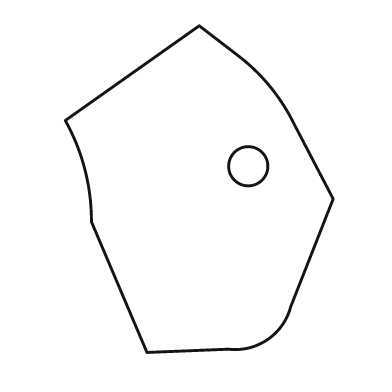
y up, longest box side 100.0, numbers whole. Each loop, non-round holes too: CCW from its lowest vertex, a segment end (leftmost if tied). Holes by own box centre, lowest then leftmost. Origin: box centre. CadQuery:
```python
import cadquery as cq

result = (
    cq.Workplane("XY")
    .moveTo(-16.0, -50.0)
    .lineTo(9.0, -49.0)
    .threePointArc((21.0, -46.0), (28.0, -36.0))
    .lineTo(41.0, -3.0)
    .lineTo(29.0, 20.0)
    .threePointArc((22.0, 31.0), (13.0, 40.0))
    .lineTo(0.0, 50.0)
    .lineTo(-41.0, 21.0)
    .threePointArc((-35.0, 6.0), (-33.0, -10.0))
    .close()
    .moveTo(15.0, 7.0)
    .circle(6.0)
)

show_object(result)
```